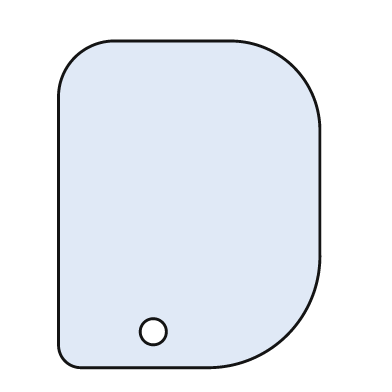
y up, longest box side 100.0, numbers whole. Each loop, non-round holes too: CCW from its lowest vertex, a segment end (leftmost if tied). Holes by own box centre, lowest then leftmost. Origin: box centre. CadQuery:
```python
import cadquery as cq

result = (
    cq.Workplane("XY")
    .moveTo(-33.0, -50.0)
    .lineTo(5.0, -50.0)
    .threePointArc((30.0, -40.0), (40.0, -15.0))
    .lineTo(40.0, 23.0)
    .threePointArc((32.0, 42.0), (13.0, 50.0))
    .lineTo(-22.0, 50.0)
    .threePointArc((-35.0, 45.0), (-40.0, 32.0))
    .lineTo(-40.0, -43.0)
    .threePointArc((-38.0, -48.0), (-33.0, -50.0))
    .close()
    .moveTo(-11.0, -39.0)
    .circle(4.0)
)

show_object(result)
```